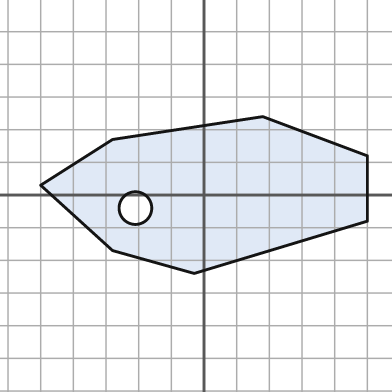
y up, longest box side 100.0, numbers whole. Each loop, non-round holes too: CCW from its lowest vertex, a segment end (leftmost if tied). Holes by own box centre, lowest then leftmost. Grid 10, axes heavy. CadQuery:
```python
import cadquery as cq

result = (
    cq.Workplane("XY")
    .moveTo(-3.0, -24.0)
    .lineTo(50.0, -8.0)
    .lineTo(50.0, 12.0)
    .lineTo(18.0, 24.0)
    .lineTo(-28.0, 17.0)
    .lineTo(-50.0, 3.0)
    .lineTo(-28.0, -17.0)
    .close()
    .moveTo(-21.0, -4.0)
    .circle(5.0)
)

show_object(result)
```